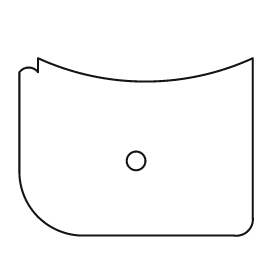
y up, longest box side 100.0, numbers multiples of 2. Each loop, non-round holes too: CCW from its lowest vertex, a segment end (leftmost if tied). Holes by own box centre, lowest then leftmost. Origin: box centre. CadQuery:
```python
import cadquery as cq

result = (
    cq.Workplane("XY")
    .moveTo(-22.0, -38.0)
    .lineTo(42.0, -38.0)
    .threePointArc((48.0, -36.0), (50.0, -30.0))
    .lineTo(50.0, 38.0)
    .threePointArc((4.0, 28.0), (-42.0, 38.0))
    .lineTo(-42.0, 32.0)
    .threePointArc((-46.0, 34.0), (-50.0, 32.0))
    .lineTo(-50.0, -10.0)
    .threePointArc((-42.0, -30.0), (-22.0, -38.0))
    .close()
    .moveTo(0.0, -6.0)
    .circle(4.0)
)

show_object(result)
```